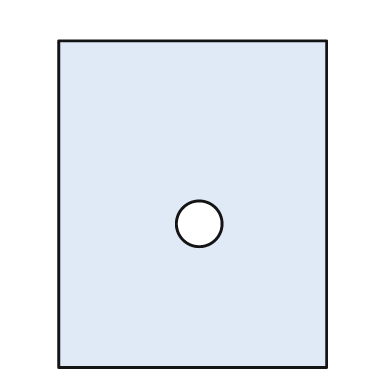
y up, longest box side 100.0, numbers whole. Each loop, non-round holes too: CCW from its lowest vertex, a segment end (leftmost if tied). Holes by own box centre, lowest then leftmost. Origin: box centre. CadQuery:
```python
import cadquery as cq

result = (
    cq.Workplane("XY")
    .moveTo(-41.0, -50.0)
    .lineTo(41.0, -50.0)
    .lineTo(41.0, 50.0)
    .lineTo(-41.0, 50.0)
    .close()
    .moveTo(2.0, -6.0)
    .circle(7.0)
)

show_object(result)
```